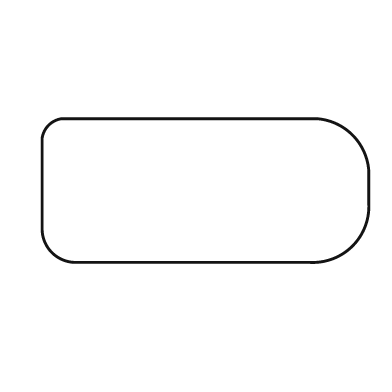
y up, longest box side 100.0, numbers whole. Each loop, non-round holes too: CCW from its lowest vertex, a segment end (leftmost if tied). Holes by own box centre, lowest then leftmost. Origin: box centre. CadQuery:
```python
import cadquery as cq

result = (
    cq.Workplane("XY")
    .moveTo(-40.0, -22.0)
    .lineTo(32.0, -22.0)
    .threePointArc((45.0, -17.0), (50.0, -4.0))
    .lineTo(50.0, 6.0)
    .threePointArc((45.0, 17.0), (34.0, 22.0))
    .lineTo(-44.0, 22.0)
    .threePointArc((-48.0, 20.0), (-50.0, 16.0))
    .lineTo(-50.0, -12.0)
    .threePointArc((-47.0, -19.0), (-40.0, -22.0))
    .close()
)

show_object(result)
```